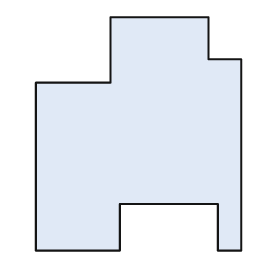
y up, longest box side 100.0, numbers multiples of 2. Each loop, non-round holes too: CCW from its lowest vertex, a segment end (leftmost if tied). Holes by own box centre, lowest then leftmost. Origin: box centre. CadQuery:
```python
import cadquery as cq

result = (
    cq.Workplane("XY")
    .moveTo(-44.0, -50.0)
    .lineTo(-8.0, -50.0)
    .lineTo(-8.0, -30.0)
    .lineTo(34.0, -30.0)
    .lineTo(34.0, -50.0)
    .lineTo(44.0, -50.0)
    .lineTo(44.0, 32.0)
    .lineTo(30.0, 32.0)
    .lineTo(30.0, 50.0)
    .lineTo(-12.0, 50.0)
    .lineTo(-12.0, 22.0)
    .lineTo(-44.0, 22.0)
    .close()
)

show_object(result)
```